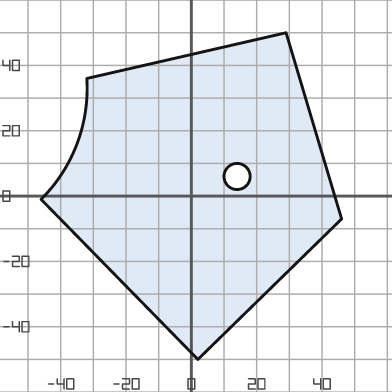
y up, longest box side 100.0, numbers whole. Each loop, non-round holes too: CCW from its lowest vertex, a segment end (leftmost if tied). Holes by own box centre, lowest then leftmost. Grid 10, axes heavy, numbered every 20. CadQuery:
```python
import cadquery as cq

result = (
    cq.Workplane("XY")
    .moveTo(2.0, -50.0)
    .lineTo(46.0, -7.0)
    .lineTo(29.0, 50.0)
    .lineTo(-32.0, 36.0)
    .threePointArc((-35.0, 16.0), (-46.0, -1.0))
    .close()
    .moveTo(14.0, 6.0)
    .circle(4.0)
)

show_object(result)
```